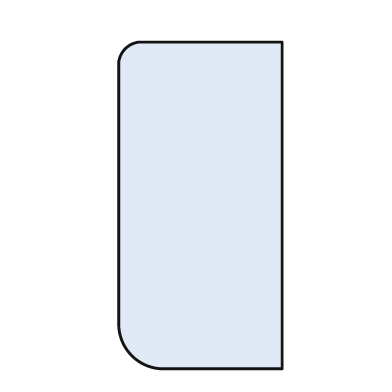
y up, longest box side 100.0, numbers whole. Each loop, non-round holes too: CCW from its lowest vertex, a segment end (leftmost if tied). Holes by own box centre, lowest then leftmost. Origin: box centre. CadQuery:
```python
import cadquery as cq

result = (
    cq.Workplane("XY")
    .moveTo(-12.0, -50.0)
    .lineTo(25.0, -50.0)
    .lineTo(25.0, 50.0)
    .lineTo(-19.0, 50.0)
    .threePointArc((-23.0, 48.0), (-25.0, 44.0))
    .lineTo(-25.0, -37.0)
    .threePointArc((-21.0, -46.0), (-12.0, -50.0))
    .close()
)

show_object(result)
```